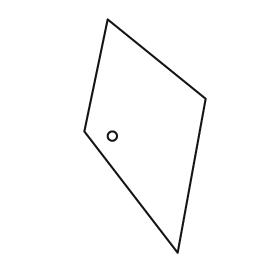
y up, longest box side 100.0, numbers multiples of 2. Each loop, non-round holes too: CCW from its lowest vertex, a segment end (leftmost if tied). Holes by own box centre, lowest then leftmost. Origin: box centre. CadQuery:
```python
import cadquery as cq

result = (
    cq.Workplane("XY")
    .moveTo(14.0, -50.0)
    .lineTo(26.0, 16.0)
    .lineTo(-16.0, 50.0)
    .lineTo(-26.0, 2.0)
    .close()
    .moveTo(-14.0, 0.0)
    .circle(2.0)
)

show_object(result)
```